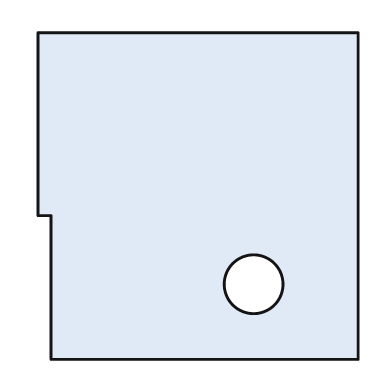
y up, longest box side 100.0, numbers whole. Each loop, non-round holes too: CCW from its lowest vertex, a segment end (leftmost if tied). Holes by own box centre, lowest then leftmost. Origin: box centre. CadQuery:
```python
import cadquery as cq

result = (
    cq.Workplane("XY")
    .moveTo(-45.0, -50.0)
    .lineTo(49.0, -50.0)
    .lineTo(49.0, 50.0)
    .lineTo(-49.0, 50.0)
    .lineTo(-49.0, -6.0)
    .lineTo(-45.0, -6.0)
    .close()
    .moveTo(17.0, -27.0)
    .circle(9.0)
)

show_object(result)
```